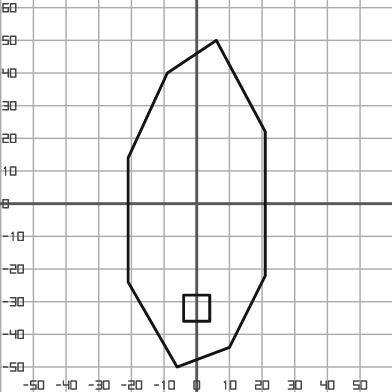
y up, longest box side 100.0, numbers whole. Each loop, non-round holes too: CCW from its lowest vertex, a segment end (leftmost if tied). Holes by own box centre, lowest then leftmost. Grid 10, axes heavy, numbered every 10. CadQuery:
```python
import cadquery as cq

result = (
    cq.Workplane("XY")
    .moveTo(-6.0, -50.0)
    .lineTo(10.0, -44.0)
    .lineTo(21.0, -22.0)
    .lineTo(21.0, 22.0)
    .lineTo(6.0, 50.0)
    .lineTo(-9.0, 40.0)
    .lineTo(-21.0, 14.0)
    .lineTo(-21.0, -24.0)
    .close()
    .moveTo(-4.0, -36.0)
    .lineTo(4.0, -36.0)
    .lineTo(4.0, -28.0)
    .lineTo(-4.0, -28.0)
    .close()
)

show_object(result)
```